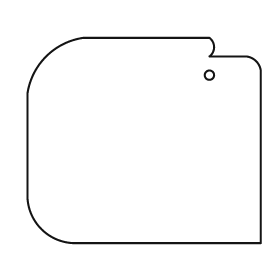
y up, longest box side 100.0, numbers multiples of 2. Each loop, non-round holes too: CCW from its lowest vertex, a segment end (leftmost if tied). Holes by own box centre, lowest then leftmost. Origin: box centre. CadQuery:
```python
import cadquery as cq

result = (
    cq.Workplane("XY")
    .moveTo(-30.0, -44.0)
    .lineTo(50.0, -44.0)
    .lineTo(50.0, 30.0)
    .threePointArc((48.0, 34.0), (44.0, 36.0))
    .lineTo(28.0, 36.0)
    .threePointArc((30.0, 40.0), (28.0, 44.0))
    .lineTo(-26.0, 44.0)
    .threePointArc((-42.0, 36.0), (-50.0, 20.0))
    .lineTo(-50.0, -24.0)
    .threePointArc((-44.0, -38.0), (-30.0, -44.0))
    .close()
    .moveTo(28.0, 28.0)
    .circle(2.0)
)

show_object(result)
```